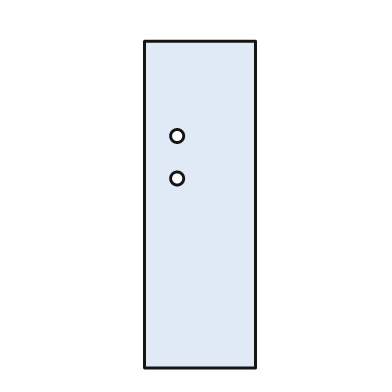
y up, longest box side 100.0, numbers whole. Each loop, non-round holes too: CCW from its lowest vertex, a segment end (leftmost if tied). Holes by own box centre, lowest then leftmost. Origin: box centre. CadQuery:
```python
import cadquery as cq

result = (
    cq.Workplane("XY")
    .moveTo(-17.0, -50.0)
    .lineTo(17.0, -50.0)
    .lineTo(17.0, 50.0)
    .lineTo(-17.0, 50.0)
    .close()
    .moveTo(-7.0, 8.0)
    .circle(2.0)
    .moveTo(-7.0, 21.0)
    .circle(2.0)
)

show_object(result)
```